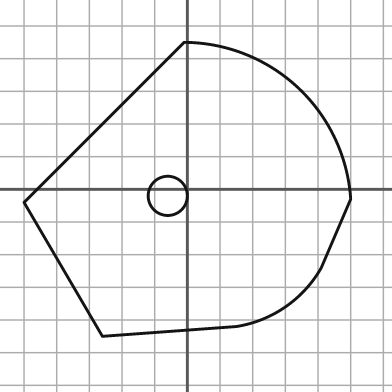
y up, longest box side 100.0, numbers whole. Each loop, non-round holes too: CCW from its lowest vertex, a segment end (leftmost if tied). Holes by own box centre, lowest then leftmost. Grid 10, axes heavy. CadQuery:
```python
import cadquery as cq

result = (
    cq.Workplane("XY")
    .moveTo(-26.0, -45.0)
    .lineTo(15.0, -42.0)
    .threePointArc((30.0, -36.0), (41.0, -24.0))
    .lineTo(50.0, -3.0)
    .threePointArc((34.0, 31.0), (-1.0, 45.0))
    .lineTo(-50.0, -4.0)
    .close()
    .moveTo(-6.0, -2.0)
    .circle(6.0)
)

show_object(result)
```